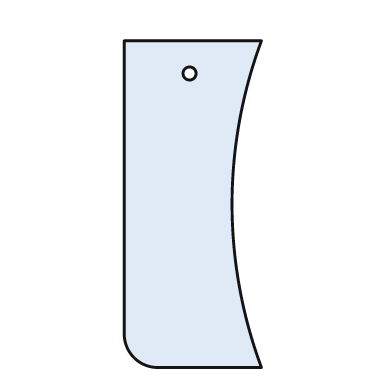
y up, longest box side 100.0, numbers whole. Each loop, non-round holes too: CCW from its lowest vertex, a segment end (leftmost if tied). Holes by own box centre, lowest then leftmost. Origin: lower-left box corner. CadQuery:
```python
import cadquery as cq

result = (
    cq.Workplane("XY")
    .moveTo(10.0, 0.0)
    .lineTo(42.0, 0.0)
    .threePointArc((33.0, 50.0), (42.0, 100.0))
    .lineTo(0.0, 100.0)
    .lineTo(0.0, 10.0)
    .threePointArc((3.0, 3.0), (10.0, 0.0))
    .close()
    .moveTo(20.0, 90.0)
    .circle(2.0)
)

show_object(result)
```